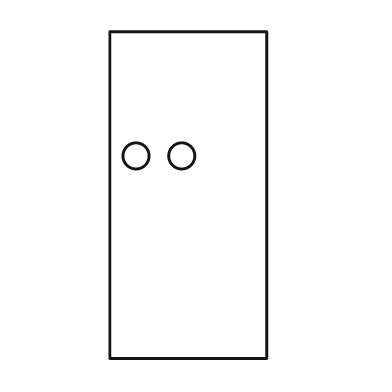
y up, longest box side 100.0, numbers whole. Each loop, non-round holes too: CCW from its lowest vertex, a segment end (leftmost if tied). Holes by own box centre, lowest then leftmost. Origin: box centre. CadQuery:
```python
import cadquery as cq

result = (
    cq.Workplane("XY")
    .moveTo(-24.0, -50.0)
    .lineTo(24.0, -50.0)
    .lineTo(24.0, 50.0)
    .lineTo(-24.0, 50.0)
    .close()
    .moveTo(-16.0, 12.0)
    .circle(4.0)
    .moveTo(-2.0, 12.0)
    .circle(4.0)
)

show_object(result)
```